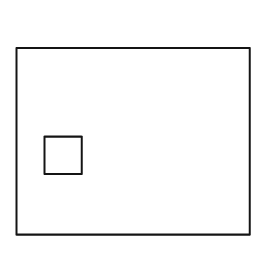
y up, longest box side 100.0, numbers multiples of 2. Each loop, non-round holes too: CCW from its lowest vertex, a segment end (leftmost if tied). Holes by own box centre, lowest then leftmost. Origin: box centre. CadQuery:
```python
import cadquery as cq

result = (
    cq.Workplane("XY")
    .moveTo(-50.0, -40.0)
    .lineTo(50.0, -40.0)
    .lineTo(50.0, 40.0)
    .lineTo(-50.0, 40.0)
    .close()
    .moveTo(-38.0, -14.0)
    .lineTo(-22.0, -14.0)
    .lineTo(-22.0, 2.0)
    .lineTo(-38.0, 2.0)
    .close()
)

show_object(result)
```